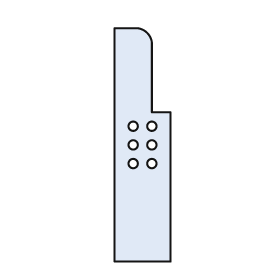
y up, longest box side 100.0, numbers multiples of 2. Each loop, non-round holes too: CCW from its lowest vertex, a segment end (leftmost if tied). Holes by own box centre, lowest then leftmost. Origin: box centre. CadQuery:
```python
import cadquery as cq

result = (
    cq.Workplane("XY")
    .moveTo(-12.0, -50.0)
    .lineTo(12.0, -50.0)
    .lineTo(12.0, 14.0)
    .lineTo(4.0, 14.0)
    .lineTo(4.0, 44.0)
    .threePointArc((2.0, 48.0), (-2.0, 50.0))
    .lineTo(-12.0, 50.0)
    .close()
    .moveTo(-4.0, -8.0)
    .circle(2.0)
    .moveTo(4.0, -8.0)
    .circle(2.0)
    .moveTo(-4.0, 0.0)
    .circle(2.0)
    .moveTo(4.0, 0.0)
    .circle(2.0)
    .moveTo(-4.0, 8.0)
    .circle(2.0)
    .moveTo(4.0, 8.0)
    .circle(2.0)
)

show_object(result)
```